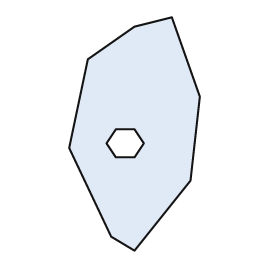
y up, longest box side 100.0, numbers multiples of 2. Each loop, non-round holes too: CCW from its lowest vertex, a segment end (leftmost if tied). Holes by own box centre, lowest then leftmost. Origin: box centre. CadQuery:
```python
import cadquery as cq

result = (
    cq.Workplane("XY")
    .moveTo(0.0, -50.0)
    .lineTo(24.0, -20.0)
    .lineTo(28.0, 16.0)
    .lineTo(16.0, 50.0)
    .lineTo(0.0, 46.0)
    .lineTo(-20.0, 32.0)
    .lineTo(-28.0, -6.0)
    .lineTo(-10.0, -44.0)
    .close()
    .moveTo(-8.0, -10.0)
    .lineTo(0.0, -10.0)
    .lineTo(4.0, -4.0)
    .lineTo(0.0, 2.0)
    .lineTo(-8.0, 2.0)
    .lineTo(-12.0, -4.0)
    .close()
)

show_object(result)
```